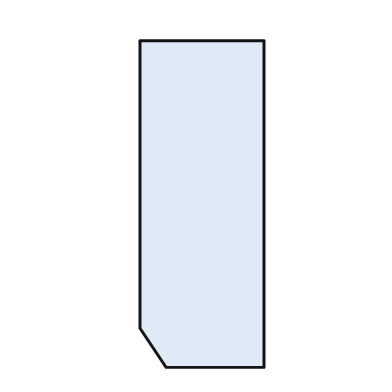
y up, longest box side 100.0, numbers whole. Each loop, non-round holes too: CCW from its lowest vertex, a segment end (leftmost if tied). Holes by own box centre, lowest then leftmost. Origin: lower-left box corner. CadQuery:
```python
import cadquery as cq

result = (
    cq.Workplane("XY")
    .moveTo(8.0, 0.0)
    .lineTo(38.0, 0.0)
    .lineTo(38.0, 100.0)
    .lineTo(0.0, 100.0)
    .lineTo(0.0, 12.0)
    .close()
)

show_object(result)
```